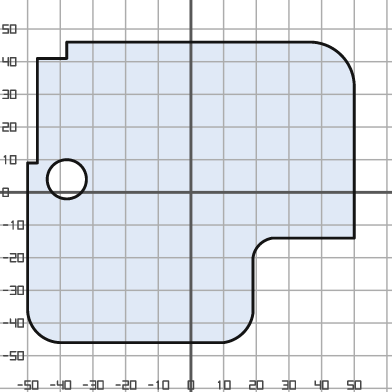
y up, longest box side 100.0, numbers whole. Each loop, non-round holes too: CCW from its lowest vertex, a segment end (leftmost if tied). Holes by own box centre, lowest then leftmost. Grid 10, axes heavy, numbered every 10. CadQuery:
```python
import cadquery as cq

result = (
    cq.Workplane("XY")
    .moveTo(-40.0, -46.0)
    .lineTo(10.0, -46.0)
    .threePointArc((16.0, -43.0), (19.0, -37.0))
    .lineTo(19.0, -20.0)
    .threePointArc((21.0, -16.0), (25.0, -14.0))
    .lineTo(50.0, -14.0)
    .lineTo(50.0, 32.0)
    .threePointArc((46.0, 42.0), (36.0, 46.0))
    .lineTo(-38.0, 46.0)
    .lineTo(-38.0, 41.0)
    .lineTo(-47.0, 41.0)
    .lineTo(-47.0, 9.0)
    .lineTo(-50.0, 9.0)
    .lineTo(-50.0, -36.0)
    .threePointArc((-47.0, -43.0), (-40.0, -46.0))
    .close()
    .moveTo(-38.0, 4.0)
    .circle(6.0)
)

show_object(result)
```